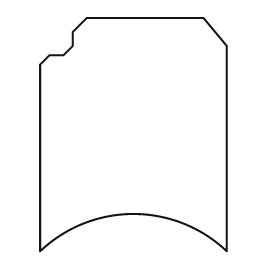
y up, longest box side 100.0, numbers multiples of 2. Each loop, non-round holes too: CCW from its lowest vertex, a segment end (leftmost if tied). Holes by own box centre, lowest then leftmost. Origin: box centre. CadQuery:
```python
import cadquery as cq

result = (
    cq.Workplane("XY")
    .moveTo(-40.0, -50.0)
    .threePointArc((0.0, -34.0), (40.0, -50.0))
    .lineTo(40.0, 38.0)
    .lineTo(30.0, 50.0)
    .lineTo(-20.0, 50.0)
    .lineTo(-26.0, 44.0)
    .lineTo(-26.0, 38.0)
    .lineTo(-30.0, 34.0)
    .lineTo(-36.0, 34.0)
    .lineTo(-40.0, 30.0)
    .close()
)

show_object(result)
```